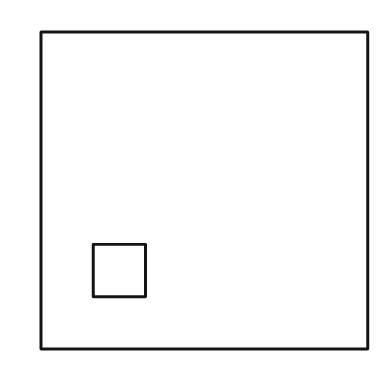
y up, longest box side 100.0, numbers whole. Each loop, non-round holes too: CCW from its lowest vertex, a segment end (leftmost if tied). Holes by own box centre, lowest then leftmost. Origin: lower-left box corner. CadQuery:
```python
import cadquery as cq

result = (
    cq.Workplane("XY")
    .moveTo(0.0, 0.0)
    .lineTo(100.0, 0.0)
    .lineTo(100.0, 97.0)
    .lineTo(0.0, 97.0)
    .close()
    .moveTo(16.0, 16.0)
    .lineTo(32.0, 16.0)
    .lineTo(32.0, 32.0)
    .lineTo(16.0, 32.0)
    .close()
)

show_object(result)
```